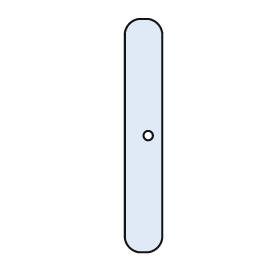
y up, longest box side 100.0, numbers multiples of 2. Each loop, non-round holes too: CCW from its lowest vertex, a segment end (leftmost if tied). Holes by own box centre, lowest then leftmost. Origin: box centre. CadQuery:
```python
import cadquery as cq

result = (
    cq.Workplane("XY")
    .moveTo(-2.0, -50.0)
    .lineTo(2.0, -50.0)
    .threePointArc((6.0, -48.0), (8.0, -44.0))
    .lineTo(8.0, 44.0)
    .threePointArc((6.0, 48.0), (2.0, 50.0))
    .lineTo(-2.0, 50.0)
    .threePointArc((-6.0, 48.0), (-8.0, 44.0))
    .lineTo(-8.0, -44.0)
    .threePointArc((-6.0, -48.0), (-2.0, -50.0))
    .close()
    .moveTo(2.0, 0.0)
    .circle(2.0)
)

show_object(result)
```